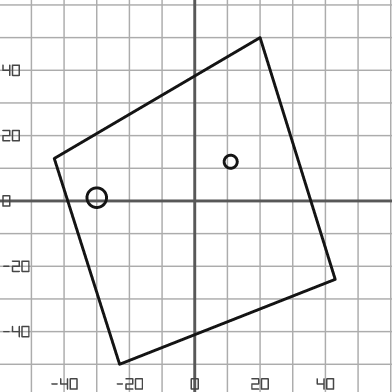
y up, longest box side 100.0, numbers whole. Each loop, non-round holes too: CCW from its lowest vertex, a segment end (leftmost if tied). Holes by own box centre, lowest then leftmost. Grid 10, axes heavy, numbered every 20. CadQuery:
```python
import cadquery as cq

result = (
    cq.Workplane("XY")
    .moveTo(-23.0, -50.0)
    .lineTo(43.0, -24.0)
    .lineTo(20.0, 50.0)
    .lineTo(-43.0, 13.0)
    .close()
    .moveTo(-30.0, 1.0)
    .circle(3.0)
    .moveTo(11.0, 12.0)
    .circle(2.0)
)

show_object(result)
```